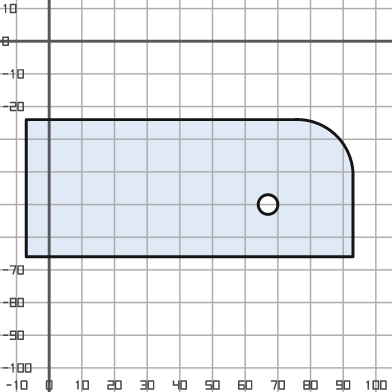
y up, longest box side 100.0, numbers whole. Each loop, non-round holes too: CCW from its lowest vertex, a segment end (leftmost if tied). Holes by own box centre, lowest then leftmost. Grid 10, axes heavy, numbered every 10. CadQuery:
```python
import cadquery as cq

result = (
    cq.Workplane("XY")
    .moveTo(-7.0, -66.0)
    .lineTo(93.0, -66.0)
    .lineTo(93.0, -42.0)
    .threePointArc((88.0, -29.0), (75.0, -24.0))
    .lineTo(-7.0, -24.0)
    .close()
    .moveTo(67.0, -50.0)
    .circle(3.0)
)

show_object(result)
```